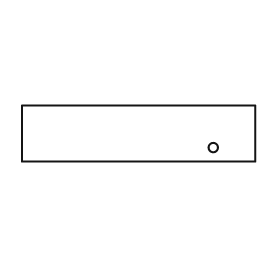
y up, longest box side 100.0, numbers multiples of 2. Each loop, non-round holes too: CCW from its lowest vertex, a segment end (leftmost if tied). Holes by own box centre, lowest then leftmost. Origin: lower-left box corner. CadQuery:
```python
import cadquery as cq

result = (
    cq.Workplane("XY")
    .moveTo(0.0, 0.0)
    .lineTo(100.0, 0.0)
    .lineTo(100.0, 24.0)
    .lineTo(0.0, 24.0)
    .close()
    .moveTo(82.0, 6.0)
    .circle(2.0)
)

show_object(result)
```